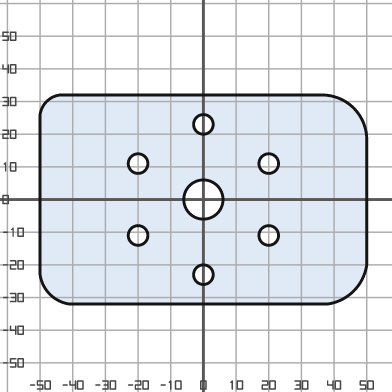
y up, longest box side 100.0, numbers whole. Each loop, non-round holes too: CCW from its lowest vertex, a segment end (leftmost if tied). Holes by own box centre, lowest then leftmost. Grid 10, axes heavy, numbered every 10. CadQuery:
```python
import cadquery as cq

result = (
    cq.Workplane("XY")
    .moveTo(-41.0, -32.0)
    .lineTo(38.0, -32.0)
    .threePointArc((46.0, -28.0), (50.0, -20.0))
    .lineTo(50.0, 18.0)
    .threePointArc((46.0, 28.0), (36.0, 32.0))
    .lineTo(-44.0, 32.0)
    .threePointArc((-48.0, 30.0), (-50.0, 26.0))
    .lineTo(-50.0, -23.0)
    .threePointArc((-47.0, -29.0), (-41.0, -32.0))
    .close()
    .moveTo(0.0, -23.0)
    .circle(3.0)
    .moveTo(-20.0, -11.0)
    .circle(3.0)
    .moveTo(20.0, -11.0)
    .circle(3.0)
    .moveTo(0.0, 0.0)
    .circle(6.0)
    .moveTo(-20.0, 11.0)
    .circle(3.0)
    .moveTo(20.0, 11.0)
    .circle(3.0)
    .moveTo(0.0, 23.0)
    .circle(3.0)
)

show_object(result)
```